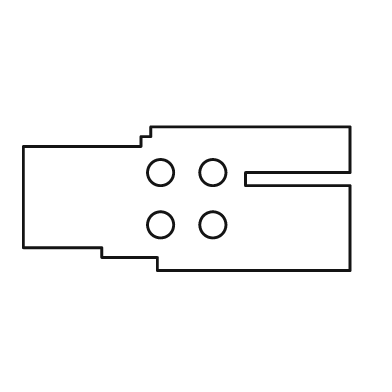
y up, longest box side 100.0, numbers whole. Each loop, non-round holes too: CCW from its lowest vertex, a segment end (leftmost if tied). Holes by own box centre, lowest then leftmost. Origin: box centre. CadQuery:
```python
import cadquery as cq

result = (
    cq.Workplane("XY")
    .moveTo(-9.0, -22.0)
    .lineTo(50.0, -22.0)
    .lineTo(50.0, 4.0)
    .lineTo(18.0, 4.0)
    .lineTo(18.0, 8.0)
    .lineTo(50.0, 8.0)
    .lineTo(50.0, 22.0)
    .lineTo(-11.0, 22.0)
    .lineTo(-11.0, 19.0)
    .lineTo(-14.0, 19.0)
    .lineTo(-14.0, 16.0)
    .lineTo(-50.0, 16.0)
    .lineTo(-50.0, -15.0)
    .lineTo(-26.0, -15.0)
    .lineTo(-26.0, -18.0)
    .lineTo(-9.0, -18.0)
    .close()
    .moveTo(-8.0, -8.0)
    .circle(4.0)
    .moveTo(8.0, -8.0)
    .circle(4.0)
    .moveTo(-8.0, 8.0)
    .circle(4.0)
    .moveTo(8.0, 8.0)
    .circle(4.0)
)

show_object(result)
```